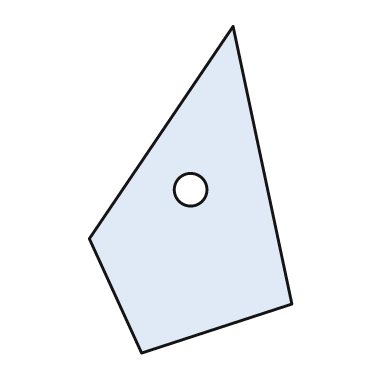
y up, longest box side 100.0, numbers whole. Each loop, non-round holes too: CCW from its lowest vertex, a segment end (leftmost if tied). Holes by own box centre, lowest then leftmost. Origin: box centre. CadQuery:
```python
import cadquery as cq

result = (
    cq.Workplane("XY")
    .moveTo(-15.0, -50.0)
    .lineTo(31.0, -35.0)
    .lineTo(13.0, 50.0)
    .lineTo(-31.0, -15.0)
    .close()
    .moveTo(0.0, 0.0)
    .circle(5.0)
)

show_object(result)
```